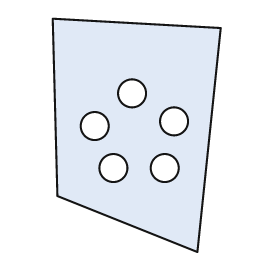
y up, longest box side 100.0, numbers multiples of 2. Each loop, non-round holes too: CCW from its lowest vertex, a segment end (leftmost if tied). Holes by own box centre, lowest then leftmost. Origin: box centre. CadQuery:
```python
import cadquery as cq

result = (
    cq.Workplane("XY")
    .moveTo(26.0, -50.0)
    .lineTo(36.0, 46.0)
    .lineTo(-36.0, 50.0)
    .lineTo(-34.0, -26.0)
    .close()
    .moveTo(-10.0, -14.0)
    .circle(6.0)
    .moveTo(12.0, -14.0)
    .circle(6.0)
    .moveTo(-18.0, 4.0)
    .circle(6.0)
    .moveTo(16.0, 6.0)
    .circle(6.0)
    .moveTo(-2.0, 18.0)
    .circle(6.0)
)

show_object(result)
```